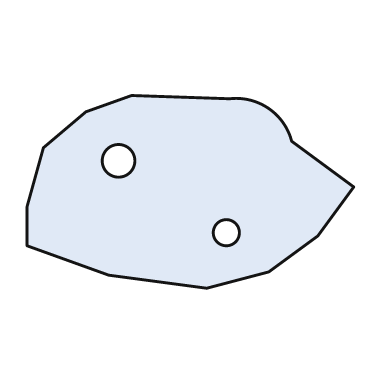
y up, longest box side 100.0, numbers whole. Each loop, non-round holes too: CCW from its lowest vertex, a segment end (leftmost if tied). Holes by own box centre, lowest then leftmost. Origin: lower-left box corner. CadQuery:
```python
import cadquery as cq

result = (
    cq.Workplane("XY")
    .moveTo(55.0, 0.0)
    .lineTo(74.0, 5.0)
    .lineTo(89.0, 16.0)
    .lineTo(100.0, 31.0)
    .lineTo(81.0, 45.0)
    .threePointArc((74.0, 55.0), (62.0, 58.0))
    .lineTo(32.0, 59.0)
    .lineTo(18.0, 54.0)
    .lineTo(5.0, 43.0)
    .lineTo(0.0, 25.0)
    .lineTo(0.0, 13.0)
    .lineTo(25.0, 4.0)
    .close()
    .moveTo(61.0, 17.0)
    .circle(4.0)
    .moveTo(28.0, 39.0)
    .circle(5.0)
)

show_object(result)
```